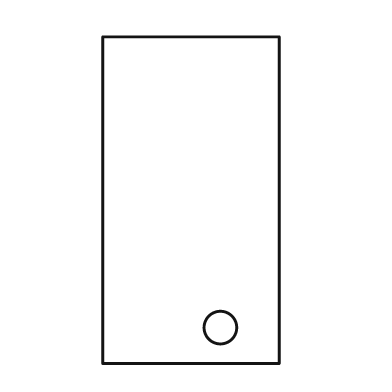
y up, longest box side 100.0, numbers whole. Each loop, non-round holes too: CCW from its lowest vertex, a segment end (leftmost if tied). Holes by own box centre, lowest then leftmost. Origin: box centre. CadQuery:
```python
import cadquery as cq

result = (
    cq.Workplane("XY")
    .moveTo(-27.0, -50.0)
    .lineTo(27.0, -50.0)
    .lineTo(27.0, 50.0)
    .lineTo(-27.0, 50.0)
    .close()
    .moveTo(9.0, -39.0)
    .circle(5.0)
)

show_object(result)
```